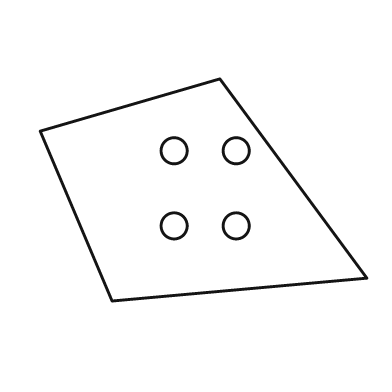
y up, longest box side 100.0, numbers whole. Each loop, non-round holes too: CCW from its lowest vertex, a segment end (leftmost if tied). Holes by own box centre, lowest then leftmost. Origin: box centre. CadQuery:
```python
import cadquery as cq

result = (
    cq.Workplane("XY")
    .moveTo(-28.0, -34.0)
    .lineTo(50.0, -27.0)
    .lineTo(5.0, 34.0)
    .lineTo(-50.0, 18.0)
    .close()
    .moveTo(-9.0, -11.0)
    .circle(4.0)
    .moveTo(10.0, -11.0)
    .circle(4.0)
    .moveTo(-9.0, 12.0)
    .circle(4.0)
    .moveTo(10.0, 12.0)
    .circle(4.0)
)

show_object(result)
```